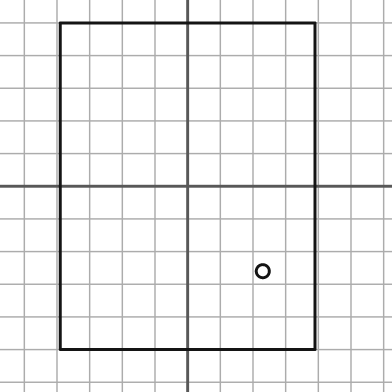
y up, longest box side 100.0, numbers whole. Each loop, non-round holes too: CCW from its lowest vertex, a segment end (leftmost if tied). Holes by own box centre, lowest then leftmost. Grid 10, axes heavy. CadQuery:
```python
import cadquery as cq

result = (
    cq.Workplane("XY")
    .moveTo(-39.0, -50.0)
    .lineTo(39.0, -50.0)
    .lineTo(39.0, 50.0)
    .lineTo(-39.0, 50.0)
    .close()
    .moveTo(23.0, -26.0)
    .circle(2.0)
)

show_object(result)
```